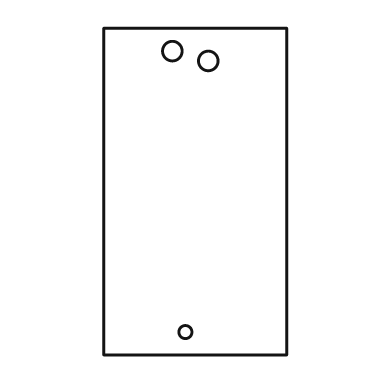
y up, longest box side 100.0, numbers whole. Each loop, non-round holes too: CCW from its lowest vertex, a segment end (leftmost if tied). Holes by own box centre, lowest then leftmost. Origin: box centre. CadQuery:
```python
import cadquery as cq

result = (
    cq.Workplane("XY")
    .moveTo(-28.0, -50.0)
    .lineTo(28.0, -50.0)
    .lineTo(28.0, 50.0)
    .lineTo(-28.0, 50.0)
    .close()
    .moveTo(-3.0, -43.0)
    .circle(2.0)
    .moveTo(4.0, 40.0)
    .circle(3.0)
    .moveTo(-7.0, 43.0)
    .circle(3.0)
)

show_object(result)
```